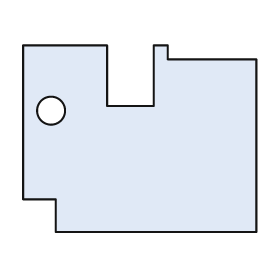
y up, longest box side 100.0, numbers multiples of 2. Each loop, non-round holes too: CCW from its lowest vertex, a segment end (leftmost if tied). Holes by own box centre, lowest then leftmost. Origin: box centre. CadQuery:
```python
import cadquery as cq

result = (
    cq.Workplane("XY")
    .moveTo(-36.0, -40.0)
    .lineTo(50.0, -40.0)
    .lineTo(50.0, 34.0)
    .lineTo(12.0, 34.0)
    .lineTo(12.0, 40.0)
    .lineTo(6.0, 40.0)
    .lineTo(6.0, 14.0)
    .lineTo(-14.0, 14.0)
    .lineTo(-14.0, 40.0)
    .lineTo(-50.0, 40.0)
    .lineTo(-50.0, -26.0)
    .lineTo(-36.0, -26.0)
    .close()
    .moveTo(-38.0, 12.0)
    .circle(6.0)
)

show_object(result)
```